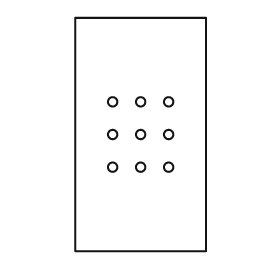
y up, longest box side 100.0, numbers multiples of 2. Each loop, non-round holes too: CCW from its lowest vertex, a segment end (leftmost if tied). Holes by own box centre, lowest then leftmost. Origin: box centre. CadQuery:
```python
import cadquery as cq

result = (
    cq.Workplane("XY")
    .moveTo(-28.0, -50.0)
    .lineTo(28.0, -50.0)
    .lineTo(28.0, 50.0)
    .lineTo(-28.0, 50.0)
    .close()
    .moveTo(-12.0, -14.0)
    .circle(2.0)
    .moveTo(0.0, -14.0)
    .circle(2.0)
    .moveTo(12.0, -14.0)
    .circle(2.0)
    .moveTo(-12.0, 0.0)
    .circle(2.0)
    .moveTo(0.0, 0.0)
    .circle(2.0)
    .moveTo(12.0, 0.0)
    .circle(2.0)
    .moveTo(-12.0, 14.0)
    .circle(2.0)
    .moveTo(0.0, 14.0)
    .circle(2.0)
    .moveTo(12.0, 14.0)
    .circle(2.0)
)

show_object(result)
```